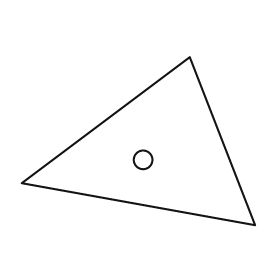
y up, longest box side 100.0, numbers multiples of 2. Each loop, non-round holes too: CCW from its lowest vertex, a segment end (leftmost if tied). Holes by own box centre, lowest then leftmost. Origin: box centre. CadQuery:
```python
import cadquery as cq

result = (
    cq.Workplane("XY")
    .moveTo(50.0, -36.0)
    .lineTo(22.0, 36.0)
    .lineTo(-50.0, -18.0)
    .close()
    .moveTo(2.0, -8.0)
    .circle(4.0)
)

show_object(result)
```